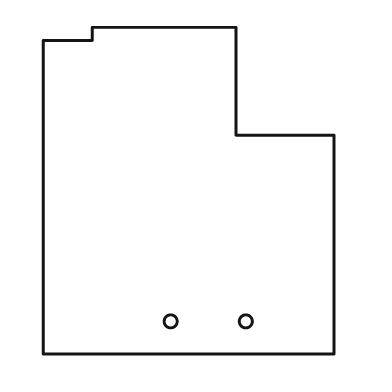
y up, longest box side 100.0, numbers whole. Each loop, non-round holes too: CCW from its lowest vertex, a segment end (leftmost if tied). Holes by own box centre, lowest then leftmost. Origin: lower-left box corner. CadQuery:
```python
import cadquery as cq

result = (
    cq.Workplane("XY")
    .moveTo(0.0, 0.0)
    .lineTo(89.0, 0.0)
    .lineTo(89.0, 67.0)
    .lineTo(59.0, 67.0)
    .lineTo(59.0, 100.0)
    .lineTo(15.0, 100.0)
    .lineTo(15.0, 96.0)
    .lineTo(0.0, 96.0)
    .close()
    .moveTo(39.0, 10.0)
    .circle(2.0)
    .moveTo(62.0, 10.0)
    .circle(2.0)
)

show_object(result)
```